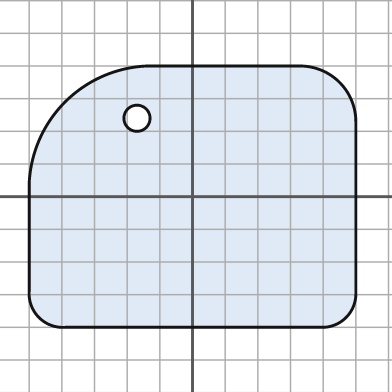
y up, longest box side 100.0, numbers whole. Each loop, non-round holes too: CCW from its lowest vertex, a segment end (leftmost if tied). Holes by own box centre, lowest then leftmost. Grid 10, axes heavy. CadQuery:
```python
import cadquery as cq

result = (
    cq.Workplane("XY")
    .moveTo(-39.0, -40.0)
    .lineTo(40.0, -40.0)
    .threePointArc((47.0, -37.0), (50.0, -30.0))
    .lineTo(50.0, 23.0)
    .threePointArc((45.0, 35.0), (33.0, 40.0))
    .lineTo(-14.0, 40.0)
    .threePointArc((-39.0, 29.0), (-50.0, 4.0))
    .lineTo(-50.0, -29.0)
    .threePointArc((-47.0, -37.0), (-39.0, -40.0))
    .close()
    .moveTo(-17.0, 24.0)
    .circle(4.0)
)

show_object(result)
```